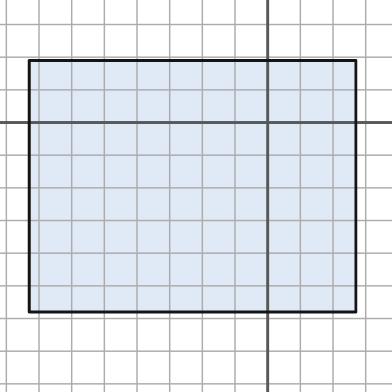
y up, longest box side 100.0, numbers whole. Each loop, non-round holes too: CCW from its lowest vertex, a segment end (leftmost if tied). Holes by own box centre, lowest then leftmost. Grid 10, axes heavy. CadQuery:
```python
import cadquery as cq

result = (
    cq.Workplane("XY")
    .moveTo(-73.0, -58.0)
    .lineTo(27.0, -58.0)
    .lineTo(27.0, 19.0)
    .lineTo(-73.0, 19.0)
    .close()
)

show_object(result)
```